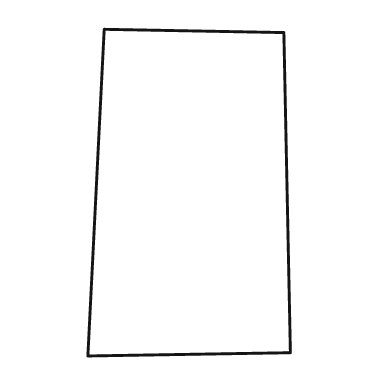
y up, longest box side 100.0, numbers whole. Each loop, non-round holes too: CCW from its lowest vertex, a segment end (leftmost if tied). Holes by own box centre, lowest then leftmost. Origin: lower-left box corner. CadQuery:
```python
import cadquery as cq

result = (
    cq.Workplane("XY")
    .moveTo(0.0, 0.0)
    .lineTo(62.0, 1.0)
    .lineTo(60.0, 99.0)
    .lineTo(5.0, 100.0)
    .close()
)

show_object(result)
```